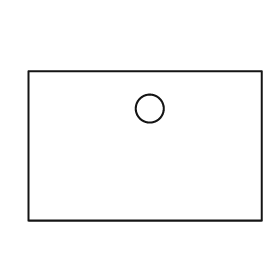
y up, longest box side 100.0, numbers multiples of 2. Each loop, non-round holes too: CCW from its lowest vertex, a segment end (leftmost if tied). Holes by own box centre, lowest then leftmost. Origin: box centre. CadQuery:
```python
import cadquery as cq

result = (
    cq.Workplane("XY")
    .moveTo(-50.0, -32.0)
    .lineTo(50.0, -32.0)
    .lineTo(50.0, 32.0)
    .lineTo(-50.0, 32.0)
    .close()
    .moveTo(2.0, 16.0)
    .circle(6.0)
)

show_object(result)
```